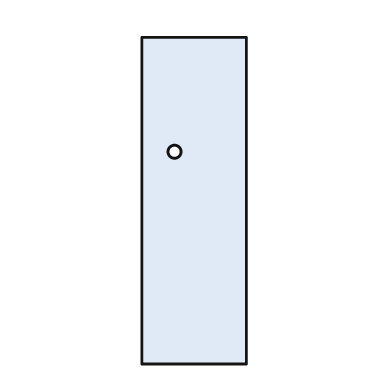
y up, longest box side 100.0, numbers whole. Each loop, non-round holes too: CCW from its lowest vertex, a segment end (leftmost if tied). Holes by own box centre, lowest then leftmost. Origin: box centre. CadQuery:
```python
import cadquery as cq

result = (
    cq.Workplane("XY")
    .moveTo(-16.0, -50.0)
    .lineTo(16.0, -50.0)
    .lineTo(16.0, 50.0)
    .lineTo(-16.0, 50.0)
    .close()
    .moveTo(-6.0, 15.0)
    .circle(2.0)
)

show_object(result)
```